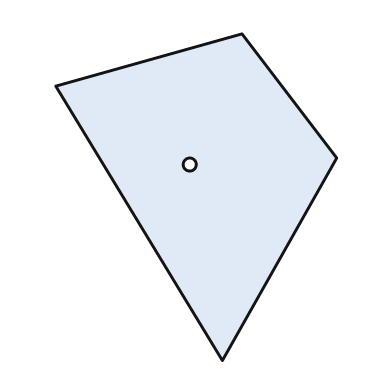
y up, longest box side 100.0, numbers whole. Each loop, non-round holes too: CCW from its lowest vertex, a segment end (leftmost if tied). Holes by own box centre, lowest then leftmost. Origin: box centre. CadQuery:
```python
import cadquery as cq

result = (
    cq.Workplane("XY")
    .moveTo(8.0, -50.0)
    .lineTo(43.0, 12.0)
    .lineTo(14.0, 50.0)
    .lineTo(-43.0, 34.0)
    .close()
    .moveTo(-2.0, 10.0)
    .circle(2.0)
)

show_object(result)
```